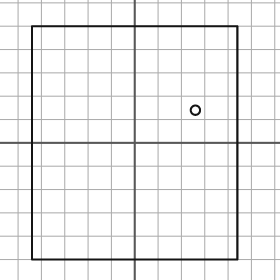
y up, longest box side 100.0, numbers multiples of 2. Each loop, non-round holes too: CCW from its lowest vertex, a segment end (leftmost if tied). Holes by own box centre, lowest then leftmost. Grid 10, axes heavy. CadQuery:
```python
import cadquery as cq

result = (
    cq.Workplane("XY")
    .moveTo(-44.0, -50.0)
    .lineTo(44.0, -50.0)
    .lineTo(44.0, 50.0)
    .lineTo(-44.0, 50.0)
    .close()
    .moveTo(26.0, 14.0)
    .circle(2.0)
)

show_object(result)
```